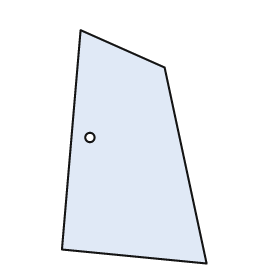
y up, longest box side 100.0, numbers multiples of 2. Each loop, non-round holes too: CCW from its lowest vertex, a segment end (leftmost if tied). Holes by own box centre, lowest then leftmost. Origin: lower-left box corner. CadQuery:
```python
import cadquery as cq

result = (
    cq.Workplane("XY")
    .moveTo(62.0, 0.0)
    .lineTo(44.0, 84.0)
    .lineTo(8.0, 100.0)
    .lineTo(0.0, 6.0)
    .close()
    .moveTo(12.0, 54.0)
    .circle(2.0)
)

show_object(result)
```